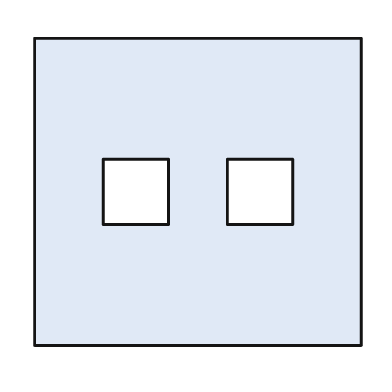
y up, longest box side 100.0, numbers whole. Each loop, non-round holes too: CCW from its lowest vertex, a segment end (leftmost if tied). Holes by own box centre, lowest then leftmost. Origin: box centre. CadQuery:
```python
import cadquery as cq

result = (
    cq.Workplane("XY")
    .moveTo(-50.0, -47.0)
    .lineTo(50.0, -47.0)
    .lineTo(50.0, 47.0)
    .lineTo(-50.0, 47.0)
    .close()
    .moveTo(-29.0, -10.0)
    .lineTo(-9.0, -10.0)
    .lineTo(-9.0, 10.0)
    .lineTo(-29.0, 10.0)
    .close()
    .moveTo(9.0, -10.0)
    .lineTo(29.0, -10.0)
    .lineTo(29.0, 10.0)
    .lineTo(9.0, 10.0)
    .close()
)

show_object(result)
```